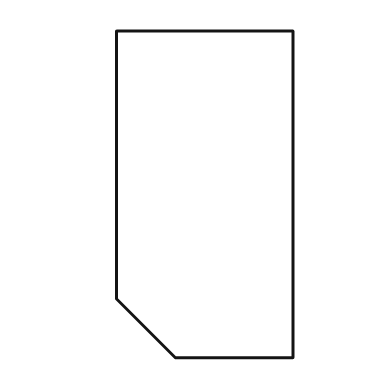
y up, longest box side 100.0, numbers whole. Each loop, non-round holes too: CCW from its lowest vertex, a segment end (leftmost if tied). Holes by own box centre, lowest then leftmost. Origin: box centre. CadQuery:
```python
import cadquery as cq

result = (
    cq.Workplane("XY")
    .moveTo(-9.0, -50.0)
    .lineTo(27.0, -50.0)
    .lineTo(27.0, 50.0)
    .lineTo(-27.0, 50.0)
    .lineTo(-27.0, -32.0)
    .close()
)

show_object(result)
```